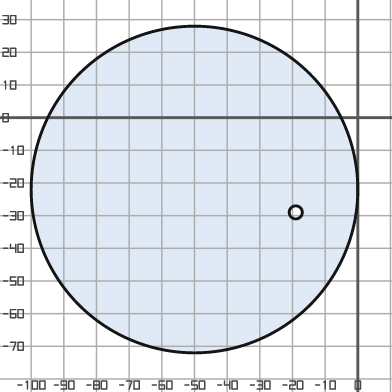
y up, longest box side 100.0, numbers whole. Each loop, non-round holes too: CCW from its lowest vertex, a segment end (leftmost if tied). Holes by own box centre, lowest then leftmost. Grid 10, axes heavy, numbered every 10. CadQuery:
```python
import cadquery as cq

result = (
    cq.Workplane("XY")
    .moveTo(-50.0, -22.0)
    .circle(50.0)
    .moveTo(-19.0, -29.0)
    .circle(2.0)
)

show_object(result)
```